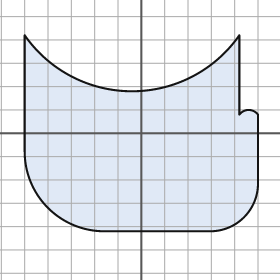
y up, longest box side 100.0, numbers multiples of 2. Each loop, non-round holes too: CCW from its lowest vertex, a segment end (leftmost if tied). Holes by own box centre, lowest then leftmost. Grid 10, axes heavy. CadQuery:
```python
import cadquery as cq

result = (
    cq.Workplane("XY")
    .moveTo(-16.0, -42.0)
    .lineTo(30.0, -42.0)
    .threePointArc((44.0, -36.0), (50.0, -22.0))
    .lineTo(50.0, 8.0)
    .threePointArc((46.0, 10.0), (42.0, 8.0))
    .lineTo(42.0, 42.0)
    .threePointArc((-4.0, 18.0), (-50.0, 42.0))
    .lineTo(-50.0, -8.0)
    .threePointArc((-40.0, -32.0), (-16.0, -42.0))
    .close()
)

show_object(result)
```